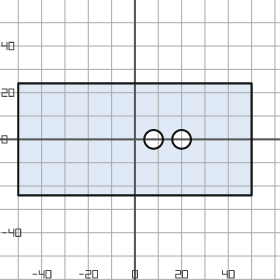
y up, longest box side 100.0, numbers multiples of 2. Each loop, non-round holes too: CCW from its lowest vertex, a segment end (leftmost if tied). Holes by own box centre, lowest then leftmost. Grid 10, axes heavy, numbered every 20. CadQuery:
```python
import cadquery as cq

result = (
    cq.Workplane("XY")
    .moveTo(-50.0, -24.0)
    .lineTo(50.0, -24.0)
    .lineTo(50.0, 24.0)
    .lineTo(-50.0, 24.0)
    .close()
    .moveTo(8.0, 0.0)
    .circle(4.0)
    .moveTo(20.0, 0.0)
    .circle(4.0)
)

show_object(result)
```